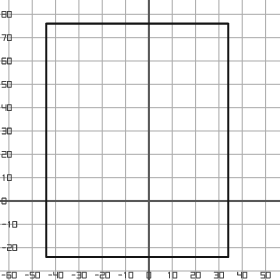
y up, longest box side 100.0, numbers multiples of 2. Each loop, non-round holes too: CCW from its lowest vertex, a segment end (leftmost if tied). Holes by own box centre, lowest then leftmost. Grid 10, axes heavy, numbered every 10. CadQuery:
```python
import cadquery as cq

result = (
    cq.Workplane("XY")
    .moveTo(-44.0, -24.0)
    .lineTo(34.0, -24.0)
    .lineTo(34.0, 76.0)
    .lineTo(-44.0, 76.0)
    .close()
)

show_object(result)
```